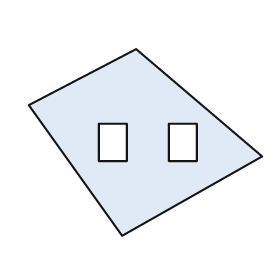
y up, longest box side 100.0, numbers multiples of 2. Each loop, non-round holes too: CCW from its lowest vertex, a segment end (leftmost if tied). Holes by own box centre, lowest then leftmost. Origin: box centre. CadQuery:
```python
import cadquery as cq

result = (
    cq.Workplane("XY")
    .moveTo(-10.0, -40.0)
    .lineTo(50.0, -6.0)
    .lineTo(-4.0, 40.0)
    .lineTo(-50.0, 16.0)
    .close()
    .moveTo(-20.0, -8.0)
    .lineTo(-8.0, -8.0)
    .lineTo(-8.0, 8.0)
    .lineTo(-20.0, 8.0)
    .close()
    .moveTo(10.0, -8.0)
    .lineTo(22.0, -8.0)
    .lineTo(22.0, 8.0)
    .lineTo(10.0, 8.0)
    .close()
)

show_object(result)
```